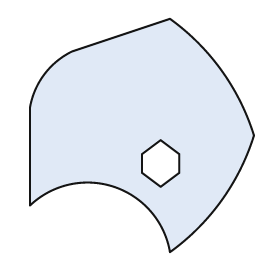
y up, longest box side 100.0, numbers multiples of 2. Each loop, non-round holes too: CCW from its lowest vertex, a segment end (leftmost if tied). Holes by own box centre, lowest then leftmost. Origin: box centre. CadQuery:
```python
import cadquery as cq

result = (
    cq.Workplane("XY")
    .moveTo(12.0, -50.0)
    .threePointArc((34.0, -28.0), (48.0, 0.0))
    .threePointArc((34.0, 28.0), (12.0, 50.0))
    .lineTo(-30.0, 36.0)
    .threePointArc((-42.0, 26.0), (-48.0, 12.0))
    .lineTo(-48.0, -30.0)
    .threePointArc((-12.0, -22.0), (12.0, -50.0))
    .close()
    .moveTo(8.0, -22.0)
    .lineTo(16.0, -16.0)
    .lineTo(16.0, -8.0)
    .lineTo(8.0, -2.0)
    .lineTo(0.0, -8.0)
    .lineTo(0.0, -16.0)
    .close()
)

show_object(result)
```